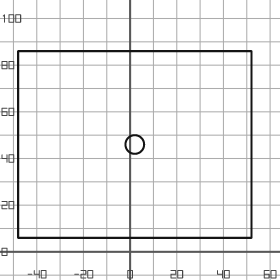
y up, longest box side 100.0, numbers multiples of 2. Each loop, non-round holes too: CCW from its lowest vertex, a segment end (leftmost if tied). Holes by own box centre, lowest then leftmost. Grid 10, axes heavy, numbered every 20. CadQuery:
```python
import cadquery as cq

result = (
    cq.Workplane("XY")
    .moveTo(-48.0, 6.0)
    .lineTo(52.0, 6.0)
    .lineTo(52.0, 86.0)
    .lineTo(-48.0, 86.0)
    .close()
    .moveTo(2.0, 46.0)
    .circle(4.0)
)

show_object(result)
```